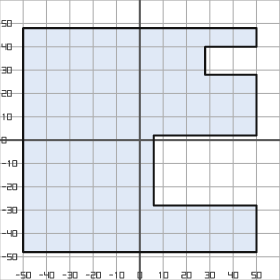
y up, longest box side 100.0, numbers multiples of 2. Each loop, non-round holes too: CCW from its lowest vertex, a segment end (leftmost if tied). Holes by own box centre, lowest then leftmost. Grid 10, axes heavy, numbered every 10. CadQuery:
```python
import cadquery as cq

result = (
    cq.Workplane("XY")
    .moveTo(-50.0, -48.0)
    .lineTo(50.0, -48.0)
    .lineTo(50.0, -28.0)
    .lineTo(6.0, -28.0)
    .lineTo(6.0, 2.0)
    .lineTo(50.0, 2.0)
    .lineTo(50.0, 28.0)
    .lineTo(28.0, 28.0)
    .lineTo(28.0, 40.0)
    .lineTo(50.0, 40.0)
    .lineTo(50.0, 48.0)
    .lineTo(-50.0, 48.0)
    .close()
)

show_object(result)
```